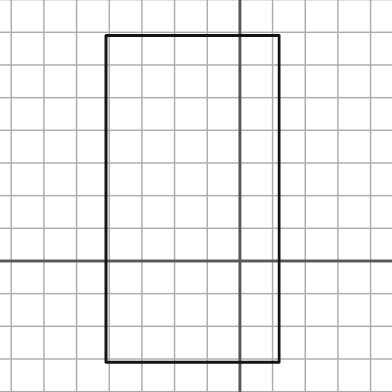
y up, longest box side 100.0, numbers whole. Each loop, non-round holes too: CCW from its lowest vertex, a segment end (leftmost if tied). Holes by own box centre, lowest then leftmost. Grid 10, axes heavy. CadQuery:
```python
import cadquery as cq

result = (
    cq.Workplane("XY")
    .moveTo(-41.0, -31.0)
    .lineTo(12.0, -31.0)
    .lineTo(12.0, 69.0)
    .lineTo(-41.0, 69.0)
    .close()
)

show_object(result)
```